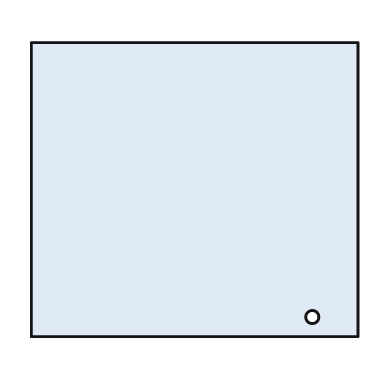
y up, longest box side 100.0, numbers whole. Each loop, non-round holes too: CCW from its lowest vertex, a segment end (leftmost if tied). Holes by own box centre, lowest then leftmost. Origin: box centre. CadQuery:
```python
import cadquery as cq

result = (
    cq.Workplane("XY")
    .moveTo(-50.0, -45.0)
    .lineTo(50.0, -45.0)
    .lineTo(50.0, 45.0)
    .lineTo(-50.0, 45.0)
    .close()
    .moveTo(36.0, -39.0)
    .circle(2.0)
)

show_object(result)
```